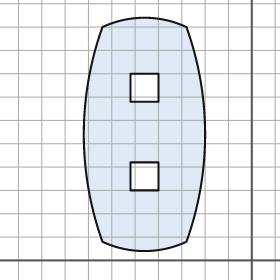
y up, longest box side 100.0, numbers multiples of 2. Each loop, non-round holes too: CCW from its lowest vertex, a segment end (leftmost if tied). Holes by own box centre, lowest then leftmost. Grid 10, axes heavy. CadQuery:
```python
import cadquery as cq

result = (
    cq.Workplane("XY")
    .moveTo(-64.0, 8.0)
    .threePointArc((-46.0, 4.0), (-28.0, 8.0))
    .threePointArc((-20.0, 54.0), (-28.0, 100.0))
    .threePointArc((-46.0, 104.0), (-64.0, 100.0))
    .threePointArc((-72.0, 54.0), (-64.0, 8.0))
    .close()
    .moveTo(-52.0, 30.0)
    .lineTo(-40.0, 30.0)
    .lineTo(-40.0, 42.0)
    .lineTo(-52.0, 42.0)
    .close()
    .moveTo(-52.0, 68.0)
    .lineTo(-40.0, 68.0)
    .lineTo(-40.0, 80.0)
    .lineTo(-52.0, 80.0)
    .close()
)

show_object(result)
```